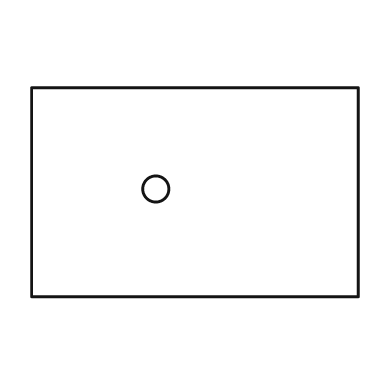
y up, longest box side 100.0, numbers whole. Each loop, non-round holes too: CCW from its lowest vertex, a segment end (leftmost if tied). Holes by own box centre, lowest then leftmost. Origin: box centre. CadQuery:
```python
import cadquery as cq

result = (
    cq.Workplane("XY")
    .moveTo(-50.0, -32.0)
    .lineTo(50.0, -32.0)
    .lineTo(50.0, 32.0)
    .lineTo(-50.0, 32.0)
    .close()
    .moveTo(-12.0, 1.0)
    .circle(4.0)
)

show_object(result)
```